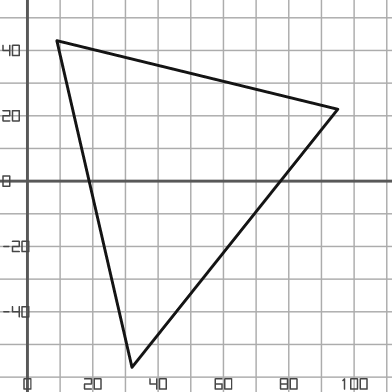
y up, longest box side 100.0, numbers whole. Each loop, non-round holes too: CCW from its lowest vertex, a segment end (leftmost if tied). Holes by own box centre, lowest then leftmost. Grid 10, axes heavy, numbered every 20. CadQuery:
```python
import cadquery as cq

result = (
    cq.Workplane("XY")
    .moveTo(32.0, -57.0)
    .lineTo(95.0, 22.0)
    .lineTo(9.0, 43.0)
    .close()
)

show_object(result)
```